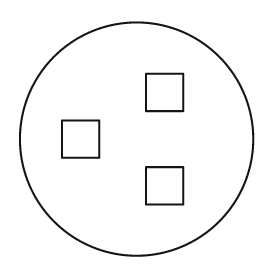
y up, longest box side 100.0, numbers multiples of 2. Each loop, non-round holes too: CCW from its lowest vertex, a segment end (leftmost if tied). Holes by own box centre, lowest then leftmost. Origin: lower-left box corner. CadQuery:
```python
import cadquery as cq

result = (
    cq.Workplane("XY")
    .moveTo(50.0, 50.0)
    .circle(50.0)
    .moveTo(54.0, 22.0)
    .lineTo(70.0, 22.0)
    .lineTo(70.0, 38.0)
    .lineTo(54.0, 38.0)
    .close()
    .moveTo(18.0, 42.0)
    .lineTo(34.0, 42.0)
    .lineTo(34.0, 58.0)
    .lineTo(18.0, 58.0)
    .close()
    .moveTo(54.0, 62.0)
    .lineTo(70.0, 62.0)
    .lineTo(70.0, 78.0)
    .lineTo(54.0, 78.0)
    .close()
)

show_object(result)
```